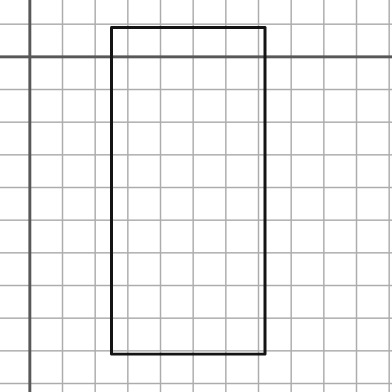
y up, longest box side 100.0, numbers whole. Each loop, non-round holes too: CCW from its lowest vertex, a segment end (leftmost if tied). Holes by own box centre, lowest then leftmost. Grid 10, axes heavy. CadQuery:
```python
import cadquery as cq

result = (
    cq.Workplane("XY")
    .moveTo(25.0, -91.0)
    .lineTo(72.0, -91.0)
    .lineTo(72.0, 9.0)
    .lineTo(25.0, 9.0)
    .close()
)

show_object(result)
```